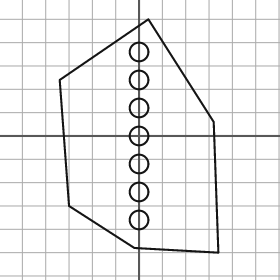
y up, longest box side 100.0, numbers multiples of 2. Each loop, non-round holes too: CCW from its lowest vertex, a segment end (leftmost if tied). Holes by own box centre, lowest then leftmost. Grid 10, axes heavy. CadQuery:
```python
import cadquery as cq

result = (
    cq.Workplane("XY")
    .moveTo(34.0, -50.0)
    .lineTo(32.0, 6.0)
    .lineTo(4.0, 50.0)
    .lineTo(-34.0, 24.0)
    .lineTo(-30.0, -30.0)
    .lineTo(-2.0, -48.0)
    .close()
    .moveTo(0.0, -36.0)
    .circle(4.0)
    .moveTo(0.0, -24.0)
    .circle(4.0)
    .moveTo(0.0, -12.0)
    .circle(4.0)
    .moveTo(0.0, 0.0)
    .circle(4.0)
    .moveTo(0.0, 12.0)
    .circle(4.0)
    .moveTo(0.0, 24.0)
    .circle(4.0)
    .moveTo(0.0, 36.0)
    .circle(4.0)
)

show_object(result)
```